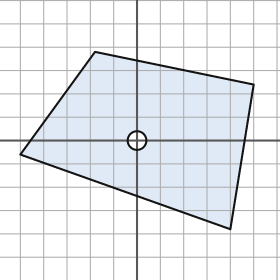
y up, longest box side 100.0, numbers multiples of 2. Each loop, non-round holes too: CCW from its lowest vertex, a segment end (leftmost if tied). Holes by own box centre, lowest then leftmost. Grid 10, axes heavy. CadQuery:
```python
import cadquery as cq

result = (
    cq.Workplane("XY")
    .moveTo(40.0, -38.0)
    .lineTo(50.0, 24.0)
    .lineTo(-18.0, 38.0)
    .lineTo(-50.0, -6.0)
    .close()
    .moveTo(0.0, 0.0)
    .circle(4.0)
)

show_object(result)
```